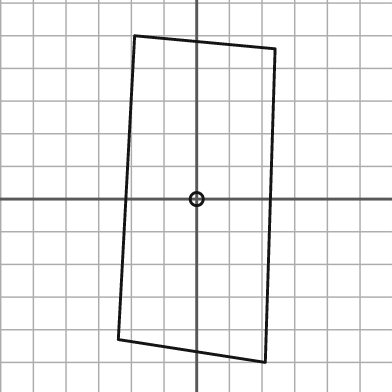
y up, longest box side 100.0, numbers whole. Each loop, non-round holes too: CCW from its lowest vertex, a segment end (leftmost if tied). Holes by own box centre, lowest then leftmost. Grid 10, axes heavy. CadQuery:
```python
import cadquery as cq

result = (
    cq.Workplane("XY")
    .moveTo(21.0, -50.0)
    .lineTo(24.0, 46.0)
    .lineTo(-19.0, 50.0)
    .lineTo(-24.0, -43.0)
    .close()
    .moveTo(0.0, 0.0)
    .circle(2.0)
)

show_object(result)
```